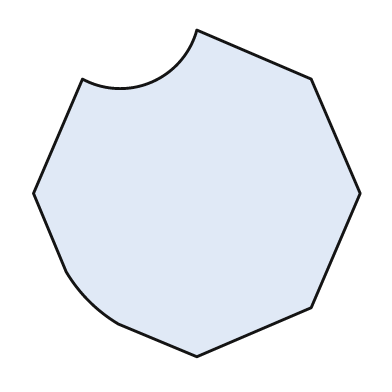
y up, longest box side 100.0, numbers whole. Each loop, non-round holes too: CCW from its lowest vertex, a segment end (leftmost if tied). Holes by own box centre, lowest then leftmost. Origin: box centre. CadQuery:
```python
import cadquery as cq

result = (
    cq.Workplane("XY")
    .moveTo(0.0, -50.0)
    .lineTo(35.0, -35.0)
    .lineTo(50.0, 0.0)
    .lineTo(35.0, 35.0)
    .lineTo(0.0, 50.0)
    .threePointArc((-14.0, 34.0), (-35.0, 35.0))
    .lineTo(-50.0, 0.0)
    .lineTo(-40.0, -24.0)
    .threePointArc((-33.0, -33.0), (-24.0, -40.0))
    .close()
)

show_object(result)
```